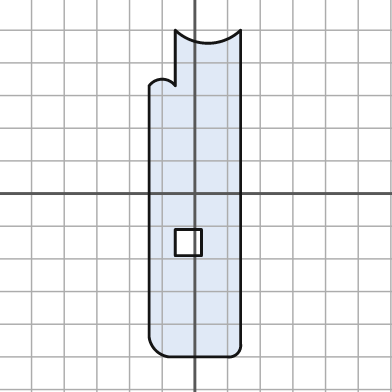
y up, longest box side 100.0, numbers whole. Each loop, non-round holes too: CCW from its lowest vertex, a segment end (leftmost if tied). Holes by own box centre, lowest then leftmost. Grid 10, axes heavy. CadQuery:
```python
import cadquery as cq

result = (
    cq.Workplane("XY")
    .moveTo(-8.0, -50.0)
    .lineTo(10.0, -50.0)
    .threePointArc((13.0, -49.0), (14.0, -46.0))
    .lineTo(14.0, 50.0)
    .threePointArc((4.0, 46.0), (-6.0, 50.0))
    .lineTo(-6.0, 33.0)
    .threePointArc((-10.0, 35.0), (-14.0, 33.0))
    .lineTo(-14.0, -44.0)
    .threePointArc((-12.0, -48.0), (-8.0, -50.0))
    .close()
    .moveTo(-6.0, -19.0)
    .lineTo(2.0, -19.0)
    .lineTo(2.0, -11.0)
    .lineTo(-6.0, -11.0)
    .close()
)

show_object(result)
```